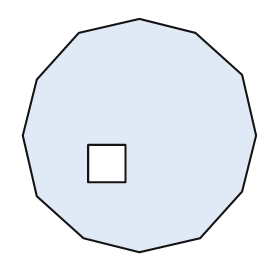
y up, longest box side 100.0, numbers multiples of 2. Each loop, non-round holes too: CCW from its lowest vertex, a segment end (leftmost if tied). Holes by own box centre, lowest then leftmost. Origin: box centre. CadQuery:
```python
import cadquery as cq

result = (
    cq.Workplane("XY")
    .moveTo(0.0, -50.0)
    .lineTo(26.0, -44.0)
    .lineTo(44.0, -24.0)
    .lineTo(50.0, 0.0)
    .lineTo(44.0, 26.0)
    .lineTo(24.0, 44.0)
    .lineTo(0.0, 50.0)
    .lineTo(-26.0, 44.0)
    .lineTo(-44.0, 24.0)
    .lineTo(-50.0, 0.0)
    .lineTo(-44.0, -26.0)
    .lineTo(-24.0, -44.0)
    .close()
    .moveTo(-22.0, -20.0)
    .lineTo(-6.0, -20.0)
    .lineTo(-6.0, -4.0)
    .lineTo(-22.0, -4.0)
    .close()
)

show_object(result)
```